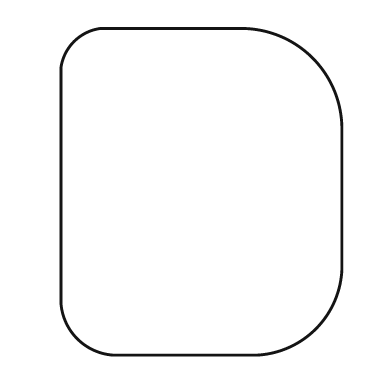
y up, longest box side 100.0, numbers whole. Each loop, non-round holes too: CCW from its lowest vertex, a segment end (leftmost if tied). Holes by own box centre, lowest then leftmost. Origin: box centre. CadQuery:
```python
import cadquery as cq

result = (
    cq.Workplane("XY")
    .moveTo(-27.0, -50.0)
    .lineTo(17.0, -50.0)
    .threePointArc((35.0, -42.0), (43.0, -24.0))
    .lineTo(43.0, 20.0)
    .threePointArc((34.0, 41.0), (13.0, 50.0))
    .lineTo(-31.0, 50.0)
    .threePointArc((-39.0, 46.0), (-43.0, 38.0))
    .lineTo(-43.0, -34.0)
    .threePointArc((-38.0, -45.0), (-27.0, -50.0))
    .close()
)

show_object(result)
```